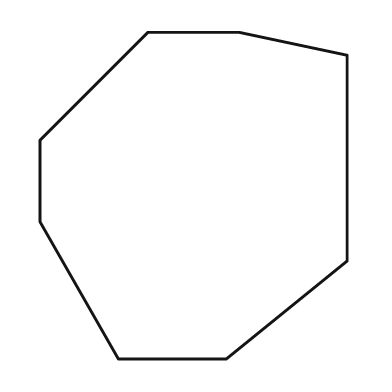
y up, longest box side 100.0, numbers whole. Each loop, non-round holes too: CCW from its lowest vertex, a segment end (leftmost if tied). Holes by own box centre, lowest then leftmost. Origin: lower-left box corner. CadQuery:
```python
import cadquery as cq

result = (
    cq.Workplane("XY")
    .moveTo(24.0, 0.0)
    .lineTo(57.0, 0.0)
    .lineTo(94.0, 30.0)
    .lineTo(94.0, 93.0)
    .lineTo(61.0, 100.0)
    .lineTo(33.0, 100.0)
    .lineTo(0.0, 67.0)
    .lineTo(0.0, 42.0)
    .close()
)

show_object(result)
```